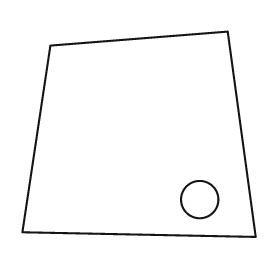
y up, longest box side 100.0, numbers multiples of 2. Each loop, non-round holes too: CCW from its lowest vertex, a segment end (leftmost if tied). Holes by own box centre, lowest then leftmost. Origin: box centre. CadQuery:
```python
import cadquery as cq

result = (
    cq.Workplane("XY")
    .moveTo(50.0, -44.0)
    .lineTo(38.0, 44.0)
    .lineTo(-38.0, 38.0)
    .lineTo(-50.0, -42.0)
    .close()
    .moveTo(26.0, -28.0)
    .circle(8.0)
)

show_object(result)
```